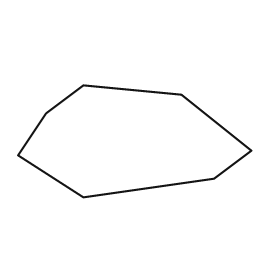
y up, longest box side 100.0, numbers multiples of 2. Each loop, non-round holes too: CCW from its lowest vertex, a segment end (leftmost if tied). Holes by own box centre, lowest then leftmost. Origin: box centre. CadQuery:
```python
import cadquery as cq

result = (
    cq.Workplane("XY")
    .moveTo(-22.0, -24.0)
    .lineTo(34.0, -16.0)
    .lineTo(50.0, -4.0)
    .lineTo(20.0, 20.0)
    .lineTo(-22.0, 24.0)
    .lineTo(-38.0, 12.0)
    .lineTo(-50.0, -6.0)
    .close()
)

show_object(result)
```